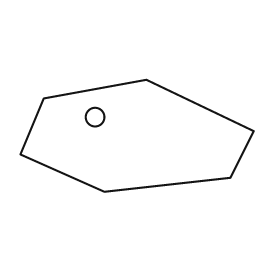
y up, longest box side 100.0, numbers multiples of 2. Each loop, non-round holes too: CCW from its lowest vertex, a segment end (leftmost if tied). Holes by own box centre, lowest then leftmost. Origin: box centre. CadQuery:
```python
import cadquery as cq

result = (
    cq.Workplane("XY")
    .moveTo(-14.0, -24.0)
    .lineTo(40.0, -18.0)
    .lineTo(50.0, 2.0)
    .lineTo(4.0, 24.0)
    .lineTo(-40.0, 16.0)
    .lineTo(-50.0, -8.0)
    .close()
    .moveTo(-18.0, 8.0)
    .circle(4.0)
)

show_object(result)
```